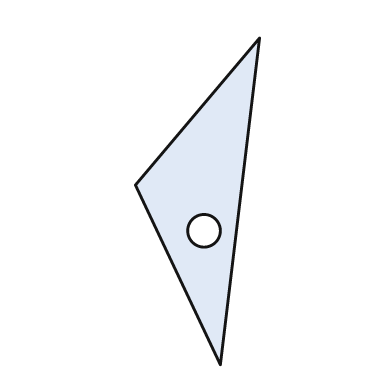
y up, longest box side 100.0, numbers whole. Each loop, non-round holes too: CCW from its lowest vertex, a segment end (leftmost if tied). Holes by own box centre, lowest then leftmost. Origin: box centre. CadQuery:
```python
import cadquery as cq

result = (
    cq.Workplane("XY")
    .moveTo(7.0, -50.0)
    .lineTo(19.0, 50.0)
    .lineTo(-19.0, 5.0)
    .close()
    .moveTo(2.0, -9.0)
    .circle(5.0)
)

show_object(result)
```